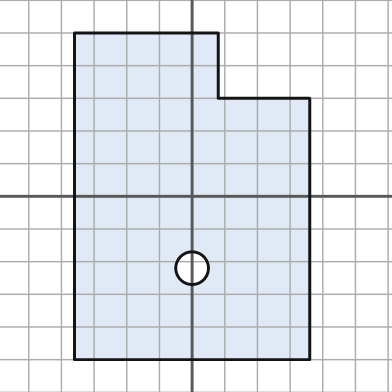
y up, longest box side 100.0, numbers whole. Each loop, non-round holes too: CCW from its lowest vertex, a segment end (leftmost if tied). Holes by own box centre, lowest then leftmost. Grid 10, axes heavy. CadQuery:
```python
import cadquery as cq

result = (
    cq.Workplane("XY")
    .moveTo(-36.0, -50.0)
    .lineTo(36.0, -50.0)
    .lineTo(36.0, 30.0)
    .lineTo(8.0, 30.0)
    .lineTo(8.0, 50.0)
    .lineTo(-36.0, 50.0)
    .close()
    .moveTo(0.0, -22.0)
    .circle(5.0)
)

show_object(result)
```